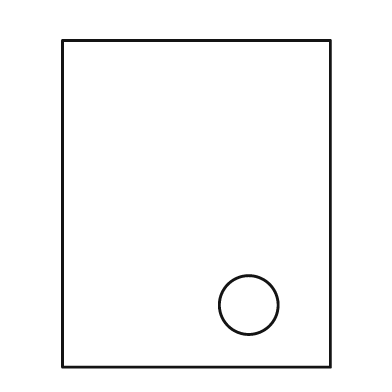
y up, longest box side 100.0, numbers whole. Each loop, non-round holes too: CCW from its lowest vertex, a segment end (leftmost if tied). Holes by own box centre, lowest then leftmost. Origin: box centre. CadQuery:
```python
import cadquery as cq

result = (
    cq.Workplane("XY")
    .moveTo(-41.0, -50.0)
    .lineTo(41.0, -50.0)
    .lineTo(41.0, 50.0)
    .lineTo(-41.0, 50.0)
    .close()
    .moveTo(16.0, -31.0)
    .circle(9.0)
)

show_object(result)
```